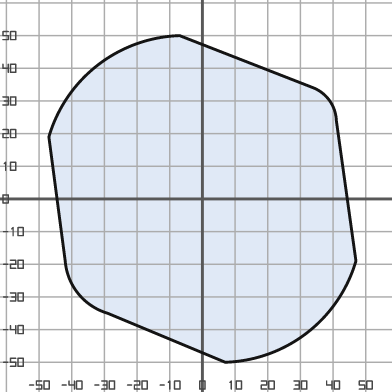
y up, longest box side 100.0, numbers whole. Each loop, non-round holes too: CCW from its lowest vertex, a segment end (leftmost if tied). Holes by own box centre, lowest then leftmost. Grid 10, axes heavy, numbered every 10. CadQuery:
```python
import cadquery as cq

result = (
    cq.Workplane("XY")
    .moveTo(7.0, -50.0)
    .threePointArc((32.0, -41.0), (47.0, -19.0))
    .lineTo(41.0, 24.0)
    .threePointArc((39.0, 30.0), (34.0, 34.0))
    .lineTo(-7.0, 50.0)
    .threePointArc((-32.0, 41.0), (-47.0, 19.0))
    .lineTo(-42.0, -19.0)
    .threePointArc((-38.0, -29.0), (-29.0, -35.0))
    .close()
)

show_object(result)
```